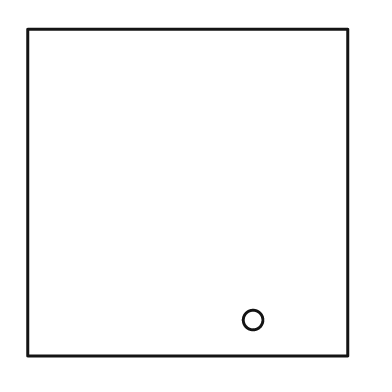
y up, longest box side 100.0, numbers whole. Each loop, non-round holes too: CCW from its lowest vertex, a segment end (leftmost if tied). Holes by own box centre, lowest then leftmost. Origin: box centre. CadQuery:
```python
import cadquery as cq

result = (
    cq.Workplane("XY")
    .moveTo(-49.0, -50.0)
    .lineTo(49.0, -50.0)
    .lineTo(49.0, 50.0)
    .lineTo(-49.0, 50.0)
    .close()
    .moveTo(20.0, -39.0)
    .circle(3.0)
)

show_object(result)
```